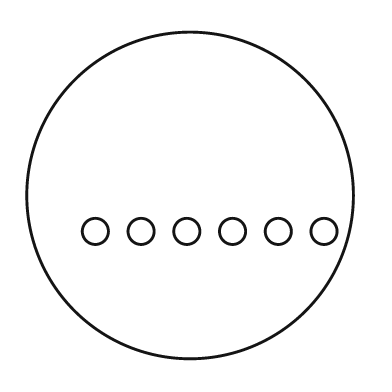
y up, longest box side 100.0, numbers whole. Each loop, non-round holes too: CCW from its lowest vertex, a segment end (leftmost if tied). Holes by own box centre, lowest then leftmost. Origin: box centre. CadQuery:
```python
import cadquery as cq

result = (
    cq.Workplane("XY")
    .moveTo(0.0, 0.0)
    .circle(50.0)
    .moveTo(-29.0, -11.0)
    .circle(4.0)
    .moveTo(-15.0, -11.0)
    .circle(4.0)
    .moveTo(-1.0, -11.0)
    .circle(4.0)
    .moveTo(13.0, -11.0)
    .circle(4.0)
    .moveTo(27.0, -11.0)
    .circle(4.0)
    .moveTo(41.0, -11.0)
    .circle(4.0)
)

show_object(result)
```